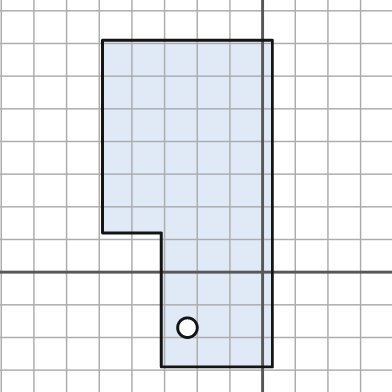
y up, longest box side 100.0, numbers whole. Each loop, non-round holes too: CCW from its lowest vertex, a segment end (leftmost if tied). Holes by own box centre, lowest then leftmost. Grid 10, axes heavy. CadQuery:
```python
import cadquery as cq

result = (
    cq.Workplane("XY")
    .moveTo(-31.0, -29.0)
    .lineTo(3.0, -29.0)
    .lineTo(3.0, 71.0)
    .lineTo(-49.0, 71.0)
    .lineTo(-49.0, 12.0)
    .lineTo(-31.0, 12.0)
    .close()
    .moveTo(-23.0, -17.0)
    .circle(3.0)
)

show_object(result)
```